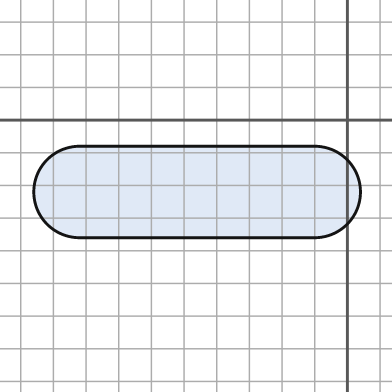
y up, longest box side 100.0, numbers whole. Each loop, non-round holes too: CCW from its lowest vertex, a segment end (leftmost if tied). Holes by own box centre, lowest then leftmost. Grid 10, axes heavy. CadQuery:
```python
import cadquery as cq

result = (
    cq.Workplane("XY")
    .moveTo(-82.0, -36.0)
    .lineTo(-10.0, -36.0)
    .threePointArc((4.0, -22.0), (-10.0, -8.0))
    .lineTo(-82.0, -8.0)
    .threePointArc((-96.0, -22.0), (-82.0, -36.0))
    .close()
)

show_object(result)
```